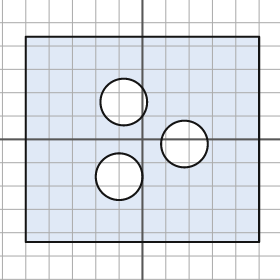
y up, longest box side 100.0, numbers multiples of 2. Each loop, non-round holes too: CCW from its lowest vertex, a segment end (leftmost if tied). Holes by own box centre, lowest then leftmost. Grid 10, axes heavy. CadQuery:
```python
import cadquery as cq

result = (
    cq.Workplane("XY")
    .moveTo(-50.0, -44.0)
    .lineTo(50.0, -44.0)
    .lineTo(50.0, 44.0)
    .lineTo(-50.0, 44.0)
    .close()
    .moveTo(-10.0, -16.0)
    .circle(10.0)
    .moveTo(18.0, -2.0)
    .circle(10.0)
    .moveTo(-8.0, 16.0)
    .circle(10.0)
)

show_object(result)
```